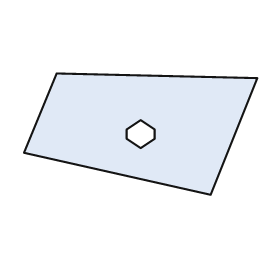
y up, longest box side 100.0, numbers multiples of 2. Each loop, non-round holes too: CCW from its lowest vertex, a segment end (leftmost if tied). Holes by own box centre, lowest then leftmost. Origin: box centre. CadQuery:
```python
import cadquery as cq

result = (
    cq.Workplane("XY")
    .moveTo(30.0, -26.0)
    .lineTo(50.0, 24.0)
    .lineTo(-36.0, 26.0)
    .lineTo(-50.0, -8.0)
    .close()
    .moveTo(0.0, -6.0)
    .lineTo(6.0, -2.0)
    .lineTo(6.0, 2.0)
    .lineTo(0.0, 6.0)
    .lineTo(-6.0, 2.0)
    .lineTo(-6.0, -2.0)
    .close()
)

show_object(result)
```